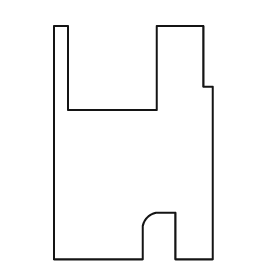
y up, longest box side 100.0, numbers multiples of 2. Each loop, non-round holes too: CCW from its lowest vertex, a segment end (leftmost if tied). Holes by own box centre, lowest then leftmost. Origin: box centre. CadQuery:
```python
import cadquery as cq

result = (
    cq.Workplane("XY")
    .moveTo(-34.0, -50.0)
    .lineTo(4.0, -50.0)
    .lineTo(4.0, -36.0)
    .threePointArc((6.0, -32.0), (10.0, -30.0))
    .lineTo(18.0, -30.0)
    .lineTo(18.0, -50.0)
    .lineTo(34.0, -50.0)
    .lineTo(34.0, 24.0)
    .lineTo(30.0, 24.0)
    .lineTo(30.0, 50.0)
    .lineTo(10.0, 50.0)
    .lineTo(10.0, 14.0)
    .lineTo(-28.0, 14.0)
    .lineTo(-28.0, 50.0)
    .lineTo(-34.0, 50.0)
    .close()
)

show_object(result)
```